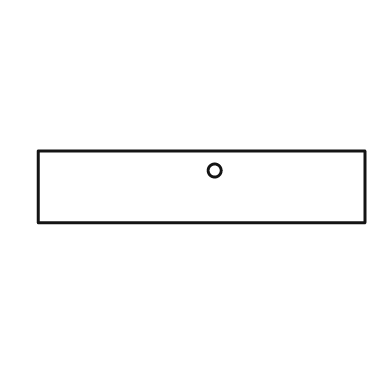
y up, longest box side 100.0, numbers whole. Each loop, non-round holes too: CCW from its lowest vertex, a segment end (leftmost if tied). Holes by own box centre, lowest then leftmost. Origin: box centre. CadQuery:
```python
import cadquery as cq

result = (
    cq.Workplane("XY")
    .moveTo(-50.0, -11.0)
    .lineTo(50.0, -11.0)
    .lineTo(50.0, 11.0)
    .lineTo(-50.0, 11.0)
    .close()
    .moveTo(4.0, 5.0)
    .circle(2.0)
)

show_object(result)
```